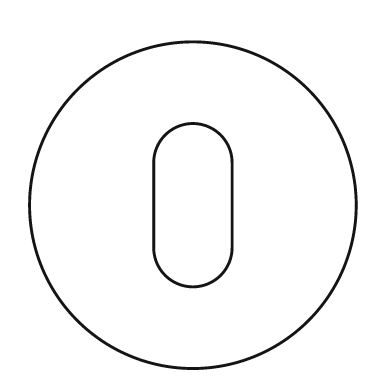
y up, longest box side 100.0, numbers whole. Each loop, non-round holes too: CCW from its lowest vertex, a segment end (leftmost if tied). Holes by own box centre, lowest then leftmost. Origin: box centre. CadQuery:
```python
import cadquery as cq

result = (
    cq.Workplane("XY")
    .moveTo(0.0, 0.0)
    .circle(50.0)
    .moveTo(-12.0, -13.0)
    .threePointArc((0.0, -25.0), (12.0, -13.0))
    .lineTo(12.0, 13.0)
    .threePointArc((0.0, 25.0), (-12.0, 13.0))
    .close()
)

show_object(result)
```